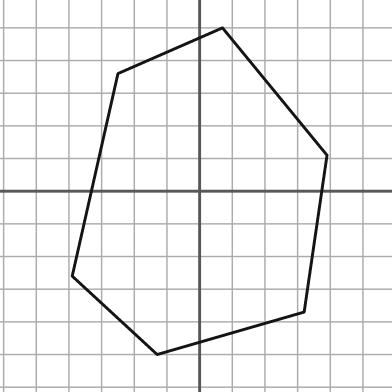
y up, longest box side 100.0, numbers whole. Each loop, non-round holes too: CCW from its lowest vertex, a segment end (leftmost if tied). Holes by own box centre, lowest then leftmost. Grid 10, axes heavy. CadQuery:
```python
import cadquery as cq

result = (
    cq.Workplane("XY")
    .moveTo(-13.0, -50.0)
    .lineTo(32.0, -37.0)
    .lineTo(39.0, 11.0)
    .lineTo(7.0, 50.0)
    .lineTo(-25.0, 36.0)
    .lineTo(-39.0, -26.0)
    .close()
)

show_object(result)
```